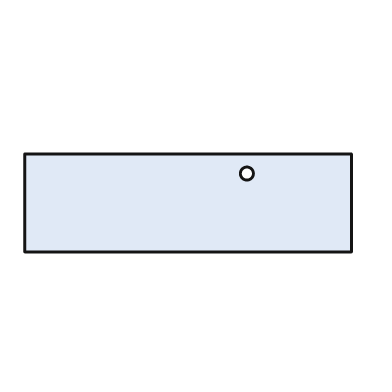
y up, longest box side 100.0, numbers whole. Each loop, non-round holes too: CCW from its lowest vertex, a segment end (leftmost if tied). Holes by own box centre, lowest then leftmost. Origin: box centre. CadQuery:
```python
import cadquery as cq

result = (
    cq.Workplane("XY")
    .moveTo(-50.0, -15.0)
    .lineTo(50.0, -15.0)
    .lineTo(50.0, 15.0)
    .lineTo(-50.0, 15.0)
    .close()
    .moveTo(18.0, 9.0)
    .circle(2.0)
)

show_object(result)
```